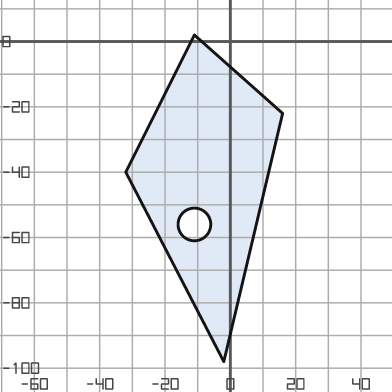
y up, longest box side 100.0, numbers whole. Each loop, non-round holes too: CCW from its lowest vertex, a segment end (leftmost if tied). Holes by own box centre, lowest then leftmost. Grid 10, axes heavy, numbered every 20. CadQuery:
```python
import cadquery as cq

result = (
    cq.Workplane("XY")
    .moveTo(-2.0, -98.0)
    .lineTo(16.0, -22.0)
    .lineTo(-11.0, 2.0)
    .lineTo(-32.0, -40.0)
    .close()
    .moveTo(-11.0, -56.0)
    .circle(5.0)
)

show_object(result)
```